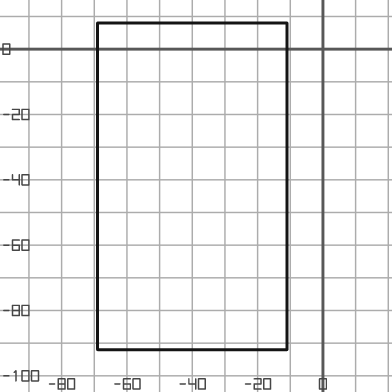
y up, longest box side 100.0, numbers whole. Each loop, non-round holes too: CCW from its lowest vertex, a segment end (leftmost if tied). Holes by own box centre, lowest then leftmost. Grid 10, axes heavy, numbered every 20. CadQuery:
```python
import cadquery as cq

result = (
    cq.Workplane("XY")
    .moveTo(-69.0, -92.0)
    .lineTo(-11.0, -92.0)
    .lineTo(-11.0, 8.0)
    .lineTo(-69.0, 8.0)
    .close()
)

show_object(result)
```